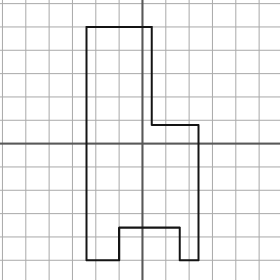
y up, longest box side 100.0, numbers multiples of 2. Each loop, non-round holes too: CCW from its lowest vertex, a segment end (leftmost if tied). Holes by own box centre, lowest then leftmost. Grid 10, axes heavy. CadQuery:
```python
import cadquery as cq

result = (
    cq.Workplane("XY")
    .moveTo(-24.0, -50.0)
    .lineTo(-10.0, -50.0)
    .lineTo(-10.0, -36.0)
    .lineTo(16.0, -36.0)
    .lineTo(16.0, -50.0)
    .lineTo(24.0, -50.0)
    .lineTo(24.0, 8.0)
    .lineTo(4.0, 8.0)
    .lineTo(4.0, 50.0)
    .lineTo(-24.0, 50.0)
    .close()
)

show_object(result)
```